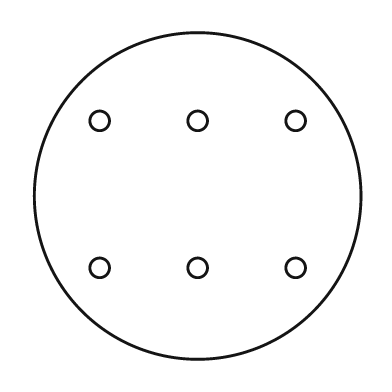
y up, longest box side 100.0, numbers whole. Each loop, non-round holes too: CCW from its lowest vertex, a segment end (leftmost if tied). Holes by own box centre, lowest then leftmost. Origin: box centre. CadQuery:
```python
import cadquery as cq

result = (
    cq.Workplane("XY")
    .moveTo(0.0, 0.0)
    .circle(50.0)
    .moveTo(-30.0, -22.0)
    .circle(3.0)
    .moveTo(0.0, -22.0)
    .circle(3.0)
    .moveTo(30.0, -22.0)
    .circle(3.0)
    .moveTo(-30.0, 23.0)
    .circle(3.0)
    .moveTo(0.0, 23.0)
    .circle(3.0)
    .moveTo(30.0, 23.0)
    .circle(3.0)
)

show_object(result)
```